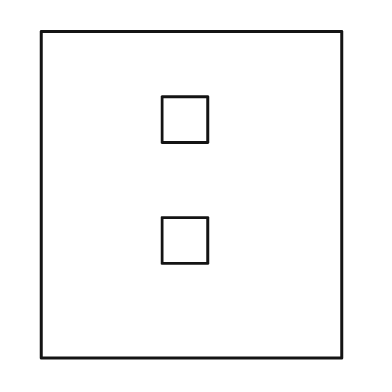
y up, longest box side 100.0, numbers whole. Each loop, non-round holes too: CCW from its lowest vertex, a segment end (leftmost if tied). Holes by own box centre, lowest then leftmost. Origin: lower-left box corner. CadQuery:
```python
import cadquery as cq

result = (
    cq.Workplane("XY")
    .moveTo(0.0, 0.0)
    .lineTo(92.0, 0.0)
    .lineTo(92.0, 100.0)
    .lineTo(0.0, 100.0)
    .close()
    .moveTo(37.0, 29.0)
    .lineTo(51.0, 29.0)
    .lineTo(51.0, 43.0)
    .lineTo(37.0, 43.0)
    .close()
    .moveTo(37.0, 66.0)
    .lineTo(51.0, 66.0)
    .lineTo(51.0, 80.0)
    .lineTo(37.0, 80.0)
    .close()
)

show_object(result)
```